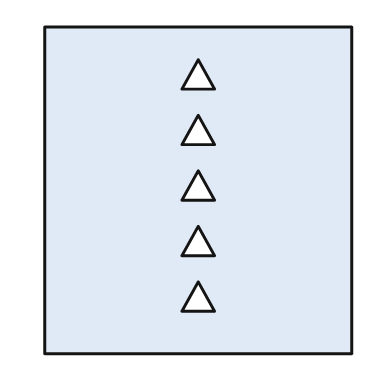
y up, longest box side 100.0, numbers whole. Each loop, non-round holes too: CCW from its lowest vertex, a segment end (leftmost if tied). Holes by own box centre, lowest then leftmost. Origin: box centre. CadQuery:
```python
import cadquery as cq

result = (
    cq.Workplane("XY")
    .moveTo(-47.0, -50.0)
    .lineTo(47.0, -50.0)
    .lineTo(47.0, 50.0)
    .lineTo(-47.0, 50.0)
    .close()
    .moveTo(-5.0, -37.0)
    .lineTo(5.0, -37.0)
    .lineTo(0.0, -28.0)
    .close()
    .moveTo(-5.0, -20.0)
    .lineTo(5.0, -20.0)
    .lineTo(0.0, -11.0)
    .close()
    .moveTo(-5.0, -3.0)
    .lineTo(5.0, -3.0)
    .lineTo(0.0, 6.0)
    .close()
    .moveTo(-5.0, 14.0)
    .lineTo(5.0, 14.0)
    .lineTo(0.0, 23.0)
    .close()
    .moveTo(-5.0, 31.0)
    .lineTo(5.0, 31.0)
    .lineTo(0.0, 40.0)
    .close()
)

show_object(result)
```